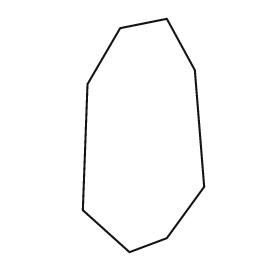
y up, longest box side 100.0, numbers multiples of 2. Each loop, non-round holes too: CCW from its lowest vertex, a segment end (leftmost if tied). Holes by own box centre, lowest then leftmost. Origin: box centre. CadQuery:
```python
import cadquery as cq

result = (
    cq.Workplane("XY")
    .moveTo(-6.0, -50.0)
    .lineTo(10.0, -44.0)
    .lineTo(26.0, -22.0)
    .lineTo(22.0, 28.0)
    .lineTo(10.0, 50.0)
    .lineTo(-10.0, 46.0)
    .lineTo(-24.0, 22.0)
    .lineTo(-26.0, -32.0)
    .close()
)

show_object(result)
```